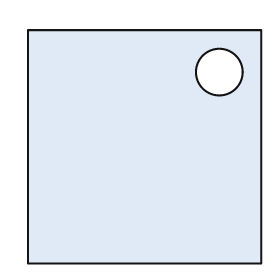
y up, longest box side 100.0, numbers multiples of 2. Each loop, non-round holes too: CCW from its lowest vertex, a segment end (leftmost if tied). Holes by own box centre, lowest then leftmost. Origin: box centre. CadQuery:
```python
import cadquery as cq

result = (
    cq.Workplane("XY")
    .moveTo(-50.0, -50.0)
    .lineTo(50.0, -50.0)
    .lineTo(50.0, 50.0)
    .lineTo(-50.0, 50.0)
    .close()
    .moveTo(32.0, 32.0)
    .circle(10.0)
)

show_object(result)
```